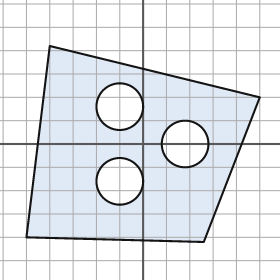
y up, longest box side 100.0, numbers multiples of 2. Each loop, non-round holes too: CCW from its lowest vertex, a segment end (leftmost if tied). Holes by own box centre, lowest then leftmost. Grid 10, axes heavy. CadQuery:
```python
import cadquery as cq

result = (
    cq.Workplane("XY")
    .moveTo(26.0, -42.0)
    .lineTo(50.0, 20.0)
    .lineTo(-40.0, 42.0)
    .lineTo(-50.0, -40.0)
    .close()
    .moveTo(-10.0, -16.0)
    .circle(10.0)
    .moveTo(18.0, 0.0)
    .circle(10.0)
    .moveTo(-10.0, 16.0)
    .circle(10.0)
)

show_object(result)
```